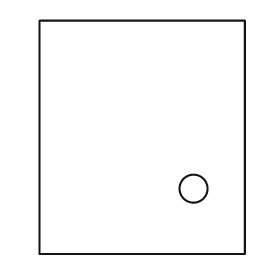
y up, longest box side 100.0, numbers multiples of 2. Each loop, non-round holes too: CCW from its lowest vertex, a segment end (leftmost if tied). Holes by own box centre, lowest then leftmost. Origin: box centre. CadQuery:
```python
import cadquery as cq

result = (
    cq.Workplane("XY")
    .moveTo(-44.0, -50.0)
    .lineTo(44.0, -50.0)
    .lineTo(44.0, 50.0)
    .lineTo(-44.0, 50.0)
    .close()
    .moveTo(22.0, -22.0)
    .circle(6.0)
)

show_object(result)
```